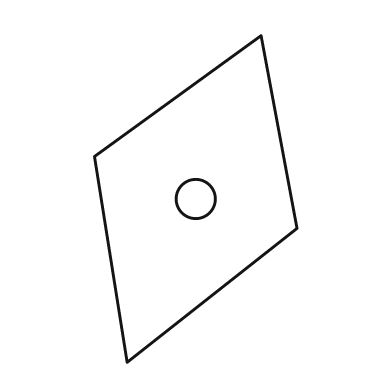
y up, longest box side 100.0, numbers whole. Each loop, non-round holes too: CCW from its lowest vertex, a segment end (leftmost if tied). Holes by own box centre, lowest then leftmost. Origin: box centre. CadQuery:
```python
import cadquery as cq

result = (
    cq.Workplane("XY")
    .moveTo(-21.0, -50.0)
    .lineTo(31.0, -9.0)
    .lineTo(20.0, 50.0)
    .lineTo(-31.0, 13.0)
    .close()
    .moveTo(0.0, 0.0)
    .circle(6.0)
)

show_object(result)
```